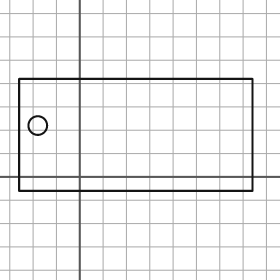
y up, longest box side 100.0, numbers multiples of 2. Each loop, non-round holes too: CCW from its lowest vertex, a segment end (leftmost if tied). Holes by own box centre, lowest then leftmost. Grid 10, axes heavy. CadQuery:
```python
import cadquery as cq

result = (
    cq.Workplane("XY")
    .moveTo(-26.0, -6.0)
    .lineTo(74.0, -6.0)
    .lineTo(74.0, 42.0)
    .lineTo(-26.0, 42.0)
    .close()
    .moveTo(-18.0, 22.0)
    .circle(4.0)
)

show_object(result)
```